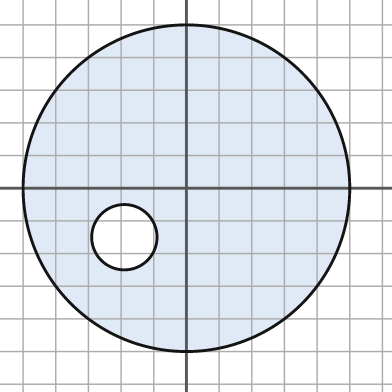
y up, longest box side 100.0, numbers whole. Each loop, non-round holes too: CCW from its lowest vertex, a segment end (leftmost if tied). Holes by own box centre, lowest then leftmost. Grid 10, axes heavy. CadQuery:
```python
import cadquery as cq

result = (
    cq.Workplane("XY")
    .moveTo(0.0, 0.0)
    .circle(50.0)
    .moveTo(-19.0, -15.0)
    .circle(10.0)
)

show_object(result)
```